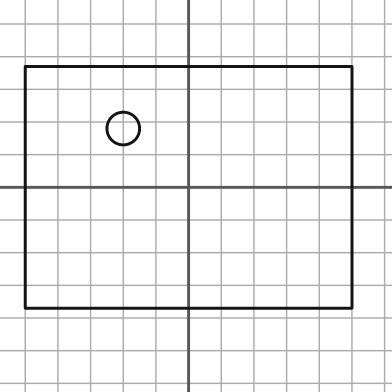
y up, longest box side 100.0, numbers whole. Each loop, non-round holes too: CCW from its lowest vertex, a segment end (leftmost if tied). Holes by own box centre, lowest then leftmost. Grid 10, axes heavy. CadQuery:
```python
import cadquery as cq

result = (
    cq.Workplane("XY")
    .moveTo(-50.0, -37.0)
    .lineTo(50.0, -37.0)
    .lineTo(50.0, 37.0)
    .lineTo(-50.0, 37.0)
    .close()
    .moveTo(-20.0, 18.0)
    .circle(5.0)
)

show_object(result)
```